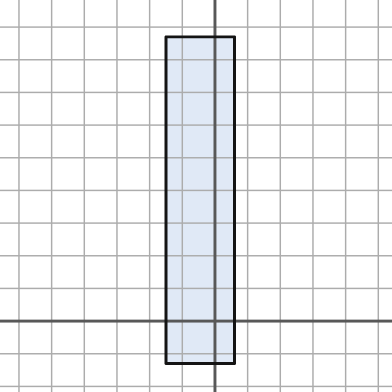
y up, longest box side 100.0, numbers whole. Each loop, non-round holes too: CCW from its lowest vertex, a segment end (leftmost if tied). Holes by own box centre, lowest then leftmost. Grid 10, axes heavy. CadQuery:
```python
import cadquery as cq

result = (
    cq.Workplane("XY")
    .moveTo(-15.0, -13.0)
    .lineTo(6.0, -13.0)
    .lineTo(6.0, 87.0)
    .lineTo(-15.0, 87.0)
    .close()
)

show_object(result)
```